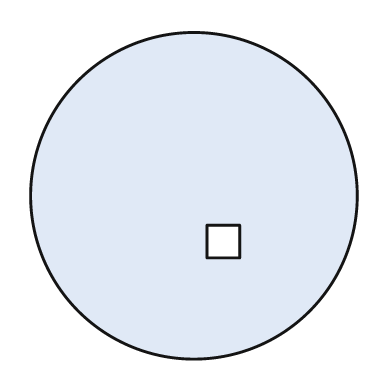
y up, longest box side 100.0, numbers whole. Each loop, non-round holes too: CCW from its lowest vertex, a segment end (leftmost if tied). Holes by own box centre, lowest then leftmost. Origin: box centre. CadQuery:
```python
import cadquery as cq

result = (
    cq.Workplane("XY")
    .moveTo(0.0, 0.0)
    .circle(50.0)
    .moveTo(4.0, -19.0)
    .lineTo(14.0, -19.0)
    .lineTo(14.0, -9.0)
    .lineTo(4.0, -9.0)
    .close()
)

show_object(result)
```